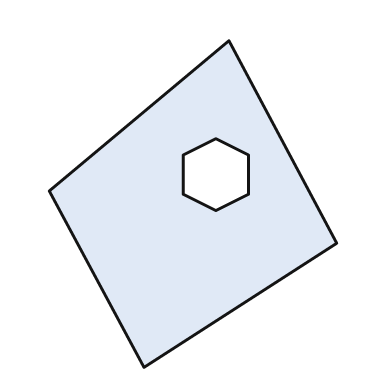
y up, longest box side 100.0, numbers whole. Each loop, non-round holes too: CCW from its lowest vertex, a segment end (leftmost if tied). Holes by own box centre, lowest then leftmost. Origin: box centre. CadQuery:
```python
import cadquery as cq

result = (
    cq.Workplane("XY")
    .moveTo(-15.0, -50.0)
    .lineTo(44.0, -12.0)
    .lineTo(11.0, 50.0)
    .lineTo(-44.0, 4.0)
    .close()
    .moveTo(7.0, -2.0)
    .lineTo(17.0, 3.0)
    .lineTo(17.0, 15.0)
    .lineTo(7.0, 20.0)
    .lineTo(-3.0, 15.0)
    .lineTo(-3.0, 3.0)
    .close()
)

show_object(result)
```